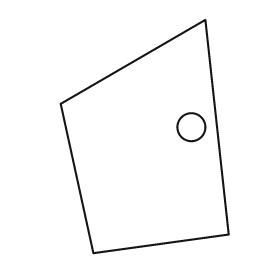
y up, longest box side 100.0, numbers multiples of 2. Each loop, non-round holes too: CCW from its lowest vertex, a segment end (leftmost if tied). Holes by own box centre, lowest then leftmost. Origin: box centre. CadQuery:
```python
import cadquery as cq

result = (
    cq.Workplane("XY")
    .moveTo(-22.0, -50.0)
    .lineTo(36.0, -42.0)
    .lineTo(26.0, 50.0)
    .lineTo(-36.0, 14.0)
    .close()
    .moveTo(20.0, 4.0)
    .circle(6.0)
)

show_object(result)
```